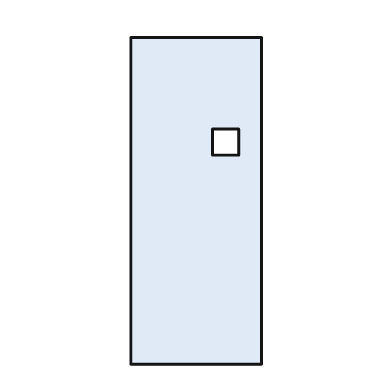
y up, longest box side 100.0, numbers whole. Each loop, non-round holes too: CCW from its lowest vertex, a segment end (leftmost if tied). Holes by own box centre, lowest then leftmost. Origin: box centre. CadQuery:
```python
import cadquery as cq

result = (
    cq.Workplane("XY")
    .moveTo(-20.0, -50.0)
    .lineTo(20.0, -50.0)
    .lineTo(20.0, 50.0)
    .lineTo(-20.0, 50.0)
    .close()
    .moveTo(5.0, 14.0)
    .lineTo(13.0, 14.0)
    .lineTo(13.0, 22.0)
    .lineTo(5.0, 22.0)
    .close()
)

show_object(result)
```